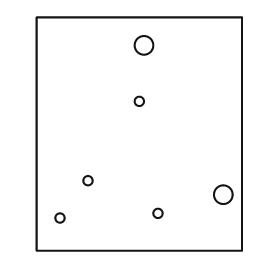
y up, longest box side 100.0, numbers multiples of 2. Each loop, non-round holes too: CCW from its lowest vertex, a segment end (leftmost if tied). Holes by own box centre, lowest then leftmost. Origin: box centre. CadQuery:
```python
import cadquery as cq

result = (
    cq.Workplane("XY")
    .moveTo(-44.0, -50.0)
    .lineTo(44.0, -50.0)
    .lineTo(44.0, 50.0)
    .lineTo(-44.0, 50.0)
    .close()
    .moveTo(-34.0, -36.0)
    .circle(2.0)
    .moveTo(8.0, -34.0)
    .circle(2.0)
    .moveTo(36.0, -26.0)
    .circle(4.0)
    .moveTo(-22.0, -20.0)
    .circle(2.0)
    .moveTo(0.0, 14.0)
    .circle(2.0)
    .moveTo(2.0, 38.0)
    .circle(4.0)
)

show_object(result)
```